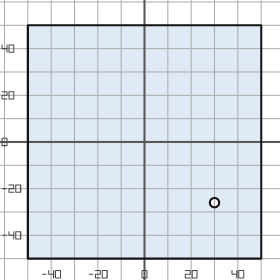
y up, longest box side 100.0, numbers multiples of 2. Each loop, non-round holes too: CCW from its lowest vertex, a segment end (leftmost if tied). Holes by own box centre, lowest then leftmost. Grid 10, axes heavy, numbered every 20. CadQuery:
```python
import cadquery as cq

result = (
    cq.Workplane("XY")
    .moveTo(-50.0, -50.0)
    .lineTo(50.0, -50.0)
    .lineTo(50.0, 50.0)
    .lineTo(-50.0, 50.0)
    .close()
    .moveTo(30.0, -26.0)
    .circle(2.0)
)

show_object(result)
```